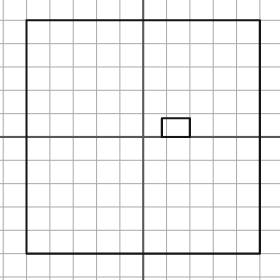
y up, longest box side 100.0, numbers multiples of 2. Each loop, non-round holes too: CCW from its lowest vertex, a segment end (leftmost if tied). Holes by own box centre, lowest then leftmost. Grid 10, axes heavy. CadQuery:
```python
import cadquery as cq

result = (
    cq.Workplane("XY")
    .moveTo(-50.0, -50.0)
    .lineTo(50.0, -50.0)
    .lineTo(50.0, 50.0)
    .lineTo(-50.0, 50.0)
    .close()
    .moveTo(8.0, 0.0)
    .lineTo(20.0, 0.0)
    .lineTo(20.0, 8.0)
    .lineTo(8.0, 8.0)
    .close()
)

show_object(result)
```